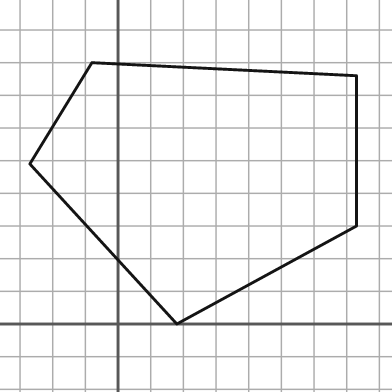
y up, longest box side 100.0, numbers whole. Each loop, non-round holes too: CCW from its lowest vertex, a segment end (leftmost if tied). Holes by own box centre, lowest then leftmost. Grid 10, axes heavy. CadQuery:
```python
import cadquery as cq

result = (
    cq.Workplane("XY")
    .moveTo(18.0, 0.0)
    .lineTo(73.0, 30.0)
    .lineTo(73.0, 76.0)
    .lineTo(-8.0, 80.0)
    .lineTo(-27.0, 49.0)
    .close()
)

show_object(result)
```